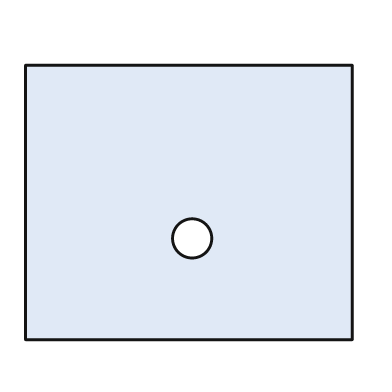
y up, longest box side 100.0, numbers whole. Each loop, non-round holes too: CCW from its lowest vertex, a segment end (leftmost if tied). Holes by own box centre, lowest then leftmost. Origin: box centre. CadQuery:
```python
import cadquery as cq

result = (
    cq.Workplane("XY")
    .moveTo(-50.0, -42.0)
    .lineTo(50.0, -42.0)
    .lineTo(50.0, 42.0)
    .lineTo(-50.0, 42.0)
    .close()
    .moveTo(1.0, -11.0)
    .circle(6.0)
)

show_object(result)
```